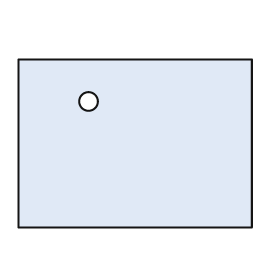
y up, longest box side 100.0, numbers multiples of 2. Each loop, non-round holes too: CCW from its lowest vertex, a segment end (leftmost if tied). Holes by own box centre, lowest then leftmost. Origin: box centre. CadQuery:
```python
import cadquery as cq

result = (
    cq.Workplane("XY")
    .moveTo(-50.0, -36.0)
    .lineTo(50.0, -36.0)
    .lineTo(50.0, 36.0)
    .lineTo(-50.0, 36.0)
    .close()
    .moveTo(-20.0, 18.0)
    .circle(4.0)
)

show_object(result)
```